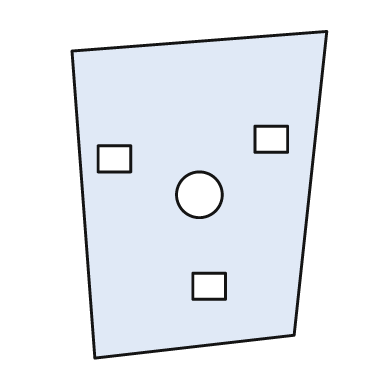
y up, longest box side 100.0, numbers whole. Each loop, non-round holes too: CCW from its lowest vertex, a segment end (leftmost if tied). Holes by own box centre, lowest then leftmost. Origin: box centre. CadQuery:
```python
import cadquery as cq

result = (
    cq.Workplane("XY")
    .moveTo(-32.0, -50.0)
    .lineTo(29.0, -43.0)
    .lineTo(39.0, 50.0)
    .lineTo(-39.0, 44.0)
    .close()
    .moveTo(-2.0, -32.0)
    .lineTo(8.0, -32.0)
    .lineTo(8.0, -24.0)
    .lineTo(-2.0, -24.0)
    .close()
    .moveTo(0.0, 0.0)
    .circle(7.0)
    .moveTo(-31.0, 7.0)
    .lineTo(-21.0, 7.0)
    .lineTo(-21.0, 15.0)
    .lineTo(-31.0, 15.0)
    .close()
    .moveTo(17.0, 13.0)
    .lineTo(27.0, 13.0)
    .lineTo(27.0, 21.0)
    .lineTo(17.0, 21.0)
    .close()
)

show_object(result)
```